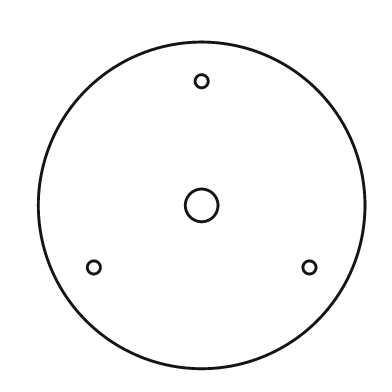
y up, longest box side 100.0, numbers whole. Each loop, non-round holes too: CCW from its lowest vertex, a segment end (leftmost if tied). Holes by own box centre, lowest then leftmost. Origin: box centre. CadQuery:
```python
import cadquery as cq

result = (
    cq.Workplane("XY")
    .moveTo(0.0, 0.0)
    .circle(50.0)
    .moveTo(-33.0, -19.0)
    .circle(2.0)
    .moveTo(33.0, -19.0)
    .circle(2.0)
    .moveTo(0.0, 0.0)
    .circle(5.0)
    .moveTo(0.0, 38.0)
    .circle(2.0)
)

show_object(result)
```